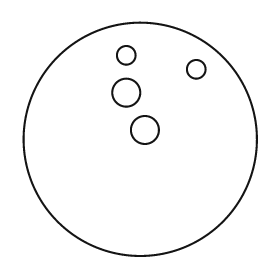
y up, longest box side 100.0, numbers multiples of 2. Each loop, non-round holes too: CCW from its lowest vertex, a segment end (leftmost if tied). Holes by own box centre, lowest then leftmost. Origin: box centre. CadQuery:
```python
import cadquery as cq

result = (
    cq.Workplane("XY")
    .moveTo(0.0, 0.0)
    .circle(50.0)
    .moveTo(2.0, 4.0)
    .circle(6.0)
    .moveTo(-6.0, 20.0)
    .circle(6.0)
    .moveTo(24.0, 30.0)
    .circle(4.0)
    .moveTo(-6.0, 36.0)
    .circle(4.0)
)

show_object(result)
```